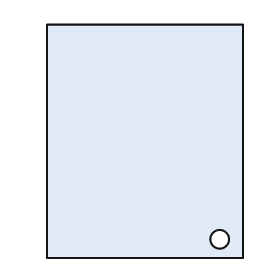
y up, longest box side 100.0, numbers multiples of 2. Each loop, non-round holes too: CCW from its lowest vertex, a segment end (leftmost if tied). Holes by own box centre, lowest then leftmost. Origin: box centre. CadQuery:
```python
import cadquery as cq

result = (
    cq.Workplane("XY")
    .moveTo(-42.0, -50.0)
    .lineTo(42.0, -50.0)
    .lineTo(42.0, 50.0)
    .lineTo(-42.0, 50.0)
    .close()
    .moveTo(32.0, -42.0)
    .circle(4.0)
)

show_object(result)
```